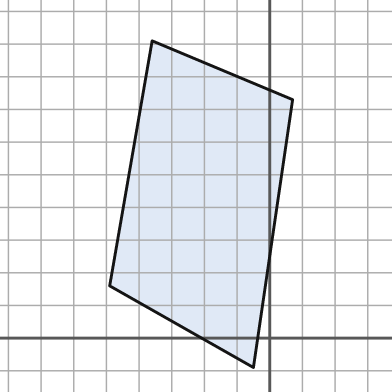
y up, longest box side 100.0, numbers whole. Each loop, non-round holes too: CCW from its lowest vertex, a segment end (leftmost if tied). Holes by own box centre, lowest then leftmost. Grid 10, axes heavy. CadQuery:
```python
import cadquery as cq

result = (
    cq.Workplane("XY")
    .moveTo(-5.0, -9.0)
    .lineTo(7.0, 73.0)
    .lineTo(-36.0, 91.0)
    .lineTo(-49.0, 16.0)
    .close()
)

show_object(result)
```